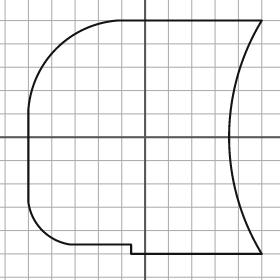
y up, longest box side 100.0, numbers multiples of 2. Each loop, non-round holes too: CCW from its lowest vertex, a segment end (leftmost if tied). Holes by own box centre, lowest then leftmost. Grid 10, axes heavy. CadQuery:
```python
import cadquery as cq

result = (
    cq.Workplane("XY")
    .moveTo(-6.0, -50.0)
    .lineTo(50.0, -50.0)
    .threePointArc((36.0, 0.0), (50.0, 50.0))
    .lineTo(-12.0, 50.0)
    .threePointArc((-38.0, 38.0), (-50.0, 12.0))
    .lineTo(-50.0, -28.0)
    .threePointArc((-44.0, -40.0), (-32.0, -46.0))
    .lineTo(-6.0, -46.0)
    .close()
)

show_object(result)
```